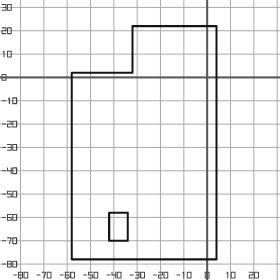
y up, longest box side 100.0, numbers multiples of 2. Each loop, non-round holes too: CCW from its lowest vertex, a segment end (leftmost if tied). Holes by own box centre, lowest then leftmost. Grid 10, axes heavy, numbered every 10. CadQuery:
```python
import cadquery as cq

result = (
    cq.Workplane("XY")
    .moveTo(-58.0, -78.0)
    .lineTo(4.0, -78.0)
    .lineTo(4.0, 22.0)
    .lineTo(-32.0, 22.0)
    .lineTo(-32.0, 2.0)
    .lineTo(-58.0, 2.0)
    .close()
    .moveTo(-42.0, -70.0)
    .lineTo(-34.0, -70.0)
    .lineTo(-34.0, -58.0)
    .lineTo(-42.0, -58.0)
    .close()
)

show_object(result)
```